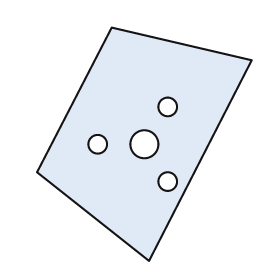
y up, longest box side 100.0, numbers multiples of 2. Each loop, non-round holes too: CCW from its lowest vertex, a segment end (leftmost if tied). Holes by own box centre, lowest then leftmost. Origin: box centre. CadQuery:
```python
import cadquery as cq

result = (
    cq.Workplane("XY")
    .moveTo(2.0, -50.0)
    .lineTo(46.0, 36.0)
    .lineTo(-14.0, 50.0)
    .lineTo(-46.0, -12.0)
    .close()
    .moveTo(10.0, -16.0)
    .circle(4.0)
    .moveTo(-20.0, 0.0)
    .circle(4.0)
    .moveTo(0.0, 0.0)
    .circle(6.0)
    .moveTo(10.0, 16.0)
    .circle(4.0)
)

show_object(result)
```